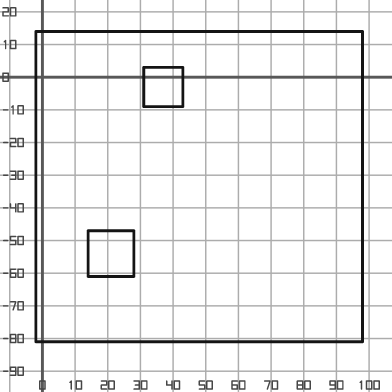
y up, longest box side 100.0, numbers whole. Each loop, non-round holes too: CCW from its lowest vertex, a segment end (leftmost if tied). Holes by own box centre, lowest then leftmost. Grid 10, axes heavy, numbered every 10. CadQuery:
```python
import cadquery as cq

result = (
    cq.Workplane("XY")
    .moveTo(-2.0, -81.0)
    .lineTo(98.0, -81.0)
    .lineTo(98.0, 14.0)
    .lineTo(-2.0, 14.0)
    .close()
    .moveTo(14.0, -61.0)
    .lineTo(28.0, -61.0)
    .lineTo(28.0, -47.0)
    .lineTo(14.0, -47.0)
    .close()
    .moveTo(31.0, -9.0)
    .lineTo(43.0, -9.0)
    .lineTo(43.0, 3.0)
    .lineTo(31.0, 3.0)
    .close()
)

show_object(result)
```